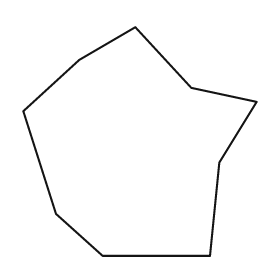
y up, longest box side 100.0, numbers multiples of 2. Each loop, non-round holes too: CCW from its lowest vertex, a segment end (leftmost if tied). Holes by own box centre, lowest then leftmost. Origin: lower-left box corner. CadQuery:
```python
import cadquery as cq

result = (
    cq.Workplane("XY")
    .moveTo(34.0, 0.0)
    .lineTo(80.0, 0.0)
    .lineTo(84.0, 40.0)
    .lineTo(100.0, 66.0)
    .lineTo(72.0, 72.0)
    .lineTo(48.0, 98.0)
    .lineTo(24.0, 84.0)
    .lineTo(0.0, 62.0)
    .lineTo(14.0, 18.0)
    .close()
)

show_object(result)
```